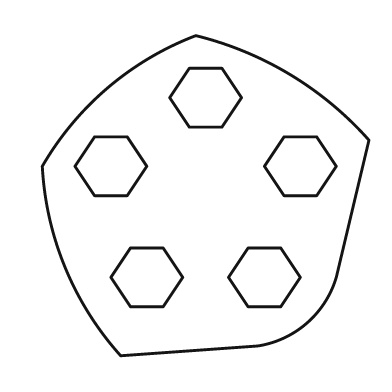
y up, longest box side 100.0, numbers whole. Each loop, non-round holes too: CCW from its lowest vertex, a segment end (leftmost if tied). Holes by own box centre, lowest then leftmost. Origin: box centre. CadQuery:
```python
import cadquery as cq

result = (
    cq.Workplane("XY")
    .moveTo(-26.0, -49.0)
    .lineTo(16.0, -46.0)
    .threePointArc((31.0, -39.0), (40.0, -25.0))
    .lineTo(50.0, 17.0)
    .threePointArc((26.0, 37.0), (-3.0, 49.0))
    .threePointArc((-30.0, 33.0), (-50.0, 9.0))
    .threePointArc((-43.0, -22.0), (-26.0, -49.0))
    .close()
    .moveTo(-23.0, -34.0)
    .lineTo(-13.0, -34.0)
    .lineTo(-7.0, -25.0)
    .lineTo(-13.0, -16.0)
    .lineTo(-23.0, -16.0)
    .lineTo(-29.0, -25.0)
    .close()
    .moveTo(13.0, -34.0)
    .lineTo(23.0, -34.0)
    .lineTo(29.0, -25.0)
    .lineTo(23.0, -16.0)
    .lineTo(13.0, -16.0)
    .lineTo(7.0, -25.0)
    .close()
    .moveTo(-34.0, 0.0)
    .lineTo(-24.0, 0.0)
    .lineTo(-18.0, 9.0)
    .lineTo(-24.0, 18.0)
    .lineTo(-34.0, 18.0)
    .lineTo(-40.0, 9.0)
    .close()
    .moveTo(24.0, 0.0)
    .lineTo(34.0, 0.0)
    .lineTo(40.0, 9.0)
    .lineTo(34.0, 18.0)
    .lineTo(24.0, 18.0)
    .lineTo(18.0, 9.0)
    .close()
    .moveTo(-5.0, 21.0)
    .lineTo(5.0, 21.0)
    .lineTo(11.0, 30.0)
    .lineTo(5.0, 39.0)
    .lineTo(-5.0, 39.0)
    .lineTo(-11.0, 30.0)
    .close()
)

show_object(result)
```